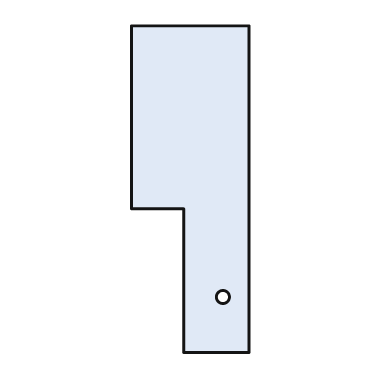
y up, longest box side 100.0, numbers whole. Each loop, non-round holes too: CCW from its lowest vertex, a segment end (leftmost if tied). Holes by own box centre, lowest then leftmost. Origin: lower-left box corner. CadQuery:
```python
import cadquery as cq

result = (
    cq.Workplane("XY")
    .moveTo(16.0, 0.0)
    .lineTo(36.0, 0.0)
    .lineTo(36.0, 100.0)
    .lineTo(0.0, 100.0)
    .lineTo(0.0, 44.0)
    .lineTo(16.0, 44.0)
    .close()
    .moveTo(28.0, 17.0)
    .circle(2.0)
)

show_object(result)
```